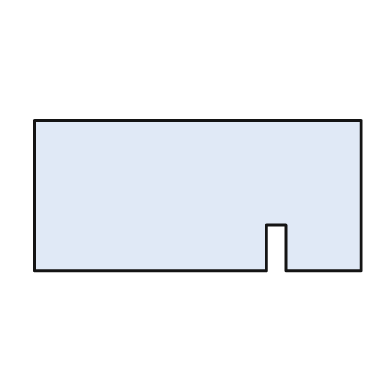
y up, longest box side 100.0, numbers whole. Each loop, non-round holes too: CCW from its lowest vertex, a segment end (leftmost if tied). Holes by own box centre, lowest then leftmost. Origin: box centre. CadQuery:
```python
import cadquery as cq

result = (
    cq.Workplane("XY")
    .moveTo(-50.0, -23.0)
    .lineTo(21.0, -23.0)
    .lineTo(21.0, -9.0)
    .lineTo(27.0, -9.0)
    .lineTo(27.0, -23.0)
    .lineTo(50.0, -23.0)
    .lineTo(50.0, 23.0)
    .lineTo(-50.0, 23.0)
    .close()
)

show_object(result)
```